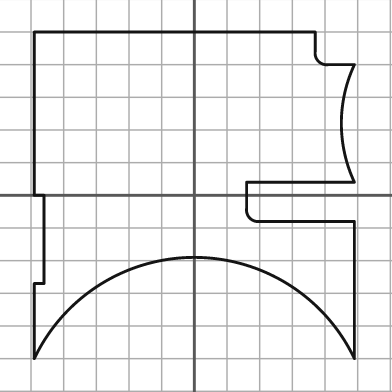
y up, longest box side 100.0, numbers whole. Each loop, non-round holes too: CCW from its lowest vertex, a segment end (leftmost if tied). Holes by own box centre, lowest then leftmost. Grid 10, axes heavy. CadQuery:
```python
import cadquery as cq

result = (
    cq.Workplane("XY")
    .moveTo(-49.0, -50.0)
    .threePointArc((0.0, -19.0), (49.0, -50.0))
    .lineTo(49.0, -8.0)
    .lineTo(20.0, -8.0)
    .threePointArc((17.0, -7.0), (16.0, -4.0))
    .lineTo(16.0, 4.0)
    .lineTo(49.0, 4.0)
    .threePointArc((45.0, 22.0), (49.0, 40.0))
    .lineTo(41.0, 40.0)
    .threePointArc((38.0, 41.0), (37.0, 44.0))
    .lineTo(37.0, 50.0)
    .lineTo(-49.0, 50.0)
    .lineTo(-49.0, 0.0)
    .lineTo(-46.0, 0.0)
    .lineTo(-46.0, -27.0)
    .lineTo(-49.0, -27.0)
    .close()
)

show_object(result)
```